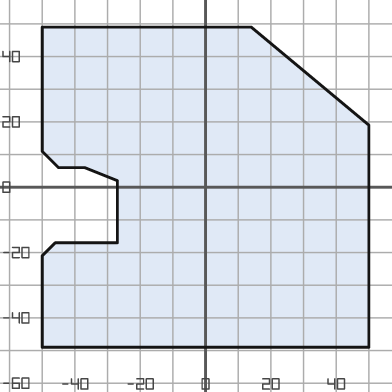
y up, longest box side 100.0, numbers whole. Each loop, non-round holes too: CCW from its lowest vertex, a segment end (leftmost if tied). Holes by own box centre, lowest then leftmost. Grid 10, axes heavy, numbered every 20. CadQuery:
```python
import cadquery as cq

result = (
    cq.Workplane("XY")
    .moveTo(-50.0, -49.0)
    .lineTo(50.0, -49.0)
    .lineTo(50.0, 19.0)
    .lineTo(14.0, 49.0)
    .lineTo(-50.0, 49.0)
    .lineTo(-50.0, 11.0)
    .lineTo(-45.0, 6.0)
    .lineTo(-37.0, 6.0)
    .lineTo(-27.0, 2.0)
    .lineTo(-27.0, -17.0)
    .lineTo(-46.0, -17.0)
    .lineTo(-50.0, -21.0)
    .close()
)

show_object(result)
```